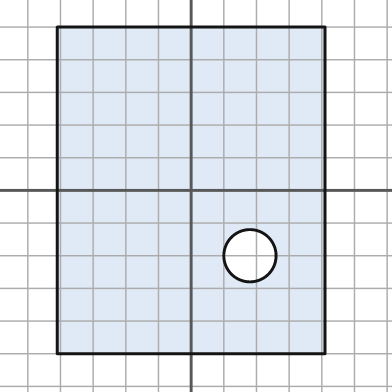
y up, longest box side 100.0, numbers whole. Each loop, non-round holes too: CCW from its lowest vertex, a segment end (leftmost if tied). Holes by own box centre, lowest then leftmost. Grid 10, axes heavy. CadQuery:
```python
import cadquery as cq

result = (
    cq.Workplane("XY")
    .moveTo(-41.0, -50.0)
    .lineTo(41.0, -50.0)
    .lineTo(41.0, 50.0)
    .lineTo(-41.0, 50.0)
    .close()
    .moveTo(18.0, -20.0)
    .circle(8.0)
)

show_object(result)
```